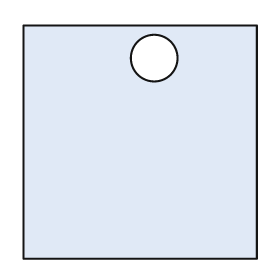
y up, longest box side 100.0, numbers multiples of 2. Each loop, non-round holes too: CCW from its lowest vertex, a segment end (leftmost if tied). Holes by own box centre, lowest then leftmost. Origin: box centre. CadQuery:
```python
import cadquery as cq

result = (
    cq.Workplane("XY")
    .moveTo(-50.0, -50.0)
    .lineTo(50.0, -50.0)
    .lineTo(50.0, 50.0)
    .lineTo(-50.0, 50.0)
    .close()
    .moveTo(6.0, 36.0)
    .circle(10.0)
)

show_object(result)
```